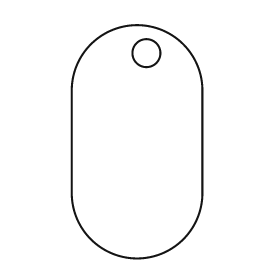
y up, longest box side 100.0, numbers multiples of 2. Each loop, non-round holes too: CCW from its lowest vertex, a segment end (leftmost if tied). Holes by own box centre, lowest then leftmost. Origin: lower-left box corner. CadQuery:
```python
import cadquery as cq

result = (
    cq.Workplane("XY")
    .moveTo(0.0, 28.0)
    .threePointArc((28.0, 0.0), (56.0, 28.0))
    .lineTo(56.0, 72.0)
    .threePointArc((28.0, 100.0), (0.0, 72.0))
    .close()
    .moveTo(32.0, 88.0)
    .circle(6.0)
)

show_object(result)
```